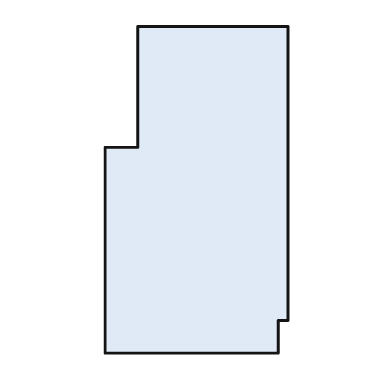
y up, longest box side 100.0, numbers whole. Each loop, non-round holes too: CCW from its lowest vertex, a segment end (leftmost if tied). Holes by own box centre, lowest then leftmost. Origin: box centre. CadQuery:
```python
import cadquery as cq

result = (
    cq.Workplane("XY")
    .moveTo(-28.0, -50.0)
    .lineTo(25.0, -50.0)
    .lineTo(25.0, -40.0)
    .lineTo(28.0, -40.0)
    .lineTo(28.0, 50.0)
    .lineTo(-18.0, 50.0)
    .lineTo(-18.0, 13.0)
    .lineTo(-28.0, 13.0)
    .close()
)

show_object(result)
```